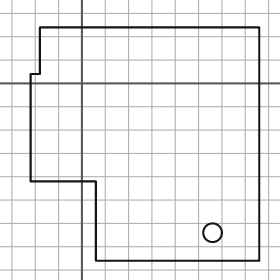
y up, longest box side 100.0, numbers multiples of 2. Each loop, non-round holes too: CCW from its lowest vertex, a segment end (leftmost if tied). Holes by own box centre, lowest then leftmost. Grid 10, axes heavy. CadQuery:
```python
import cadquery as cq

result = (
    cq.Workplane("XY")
    .moveTo(6.0, -76.0)
    .lineTo(76.0, -76.0)
    .lineTo(76.0, 24.0)
    .lineTo(-18.0, 24.0)
    .lineTo(-18.0, 4.0)
    .lineTo(-22.0, 4.0)
    .lineTo(-22.0, -42.0)
    .lineTo(6.0, -42.0)
    .close()
    .moveTo(56.0, -64.0)
    .circle(4.0)
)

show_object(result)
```